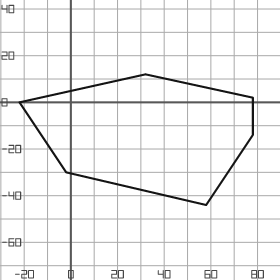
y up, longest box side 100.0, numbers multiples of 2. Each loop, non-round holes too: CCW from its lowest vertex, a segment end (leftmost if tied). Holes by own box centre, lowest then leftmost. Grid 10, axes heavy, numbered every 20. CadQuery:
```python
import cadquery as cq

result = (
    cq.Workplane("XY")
    .moveTo(58.0, -44.0)
    .lineTo(78.0, -14.0)
    .lineTo(78.0, 2.0)
    .lineTo(32.0, 12.0)
    .lineTo(-22.0, 0.0)
    .lineTo(-2.0, -30.0)
    .close()
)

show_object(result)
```